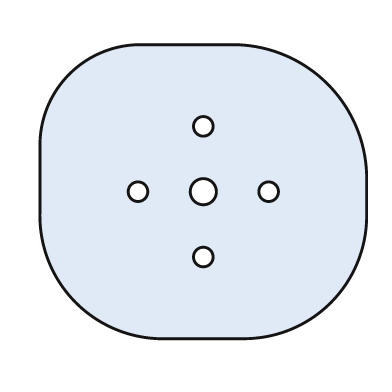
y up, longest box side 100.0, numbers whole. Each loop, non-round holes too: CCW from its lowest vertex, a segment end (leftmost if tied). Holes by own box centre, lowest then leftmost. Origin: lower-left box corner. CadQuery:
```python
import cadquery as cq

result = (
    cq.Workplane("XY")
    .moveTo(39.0, 0.0)
    .lineTo(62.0, 0.0)
    .threePointArc((89.0, 11.0), (100.0, 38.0))
    .lineTo(100.0, 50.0)
    .threePointArc((88.0, 78.0), (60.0, 90.0))
    .lineTo(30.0, 90.0)
    .threePointArc((9.0, 81.0), (0.0, 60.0))
    .lineTo(0.0, 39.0)
    .threePointArc((11.0, 11.0), (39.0, 0.0))
    .close()
    .moveTo(50.0, 25.0)
    .circle(3.0)
    .moveTo(30.0, 45.0)
    .circle(3.0)
    .moveTo(50.0, 45.0)
    .circle(4.0)
    .moveTo(70.0, 45.0)
    .circle(3.0)
    .moveTo(50.0, 65.0)
    .circle(3.0)
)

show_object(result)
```